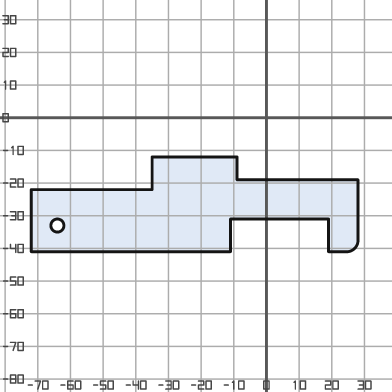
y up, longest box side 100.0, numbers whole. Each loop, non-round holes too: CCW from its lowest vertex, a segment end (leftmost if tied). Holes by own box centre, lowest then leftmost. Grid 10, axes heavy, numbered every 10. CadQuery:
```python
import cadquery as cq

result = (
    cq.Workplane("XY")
    .moveTo(-72.0, -41.0)
    .lineTo(-11.0, -41.0)
    .lineTo(-11.0, -31.0)
    .lineTo(19.0, -31.0)
    .lineTo(19.0, -41.0)
    .lineTo(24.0, -41.0)
    .threePointArc((27.0, -40.0), (28.0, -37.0))
    .lineTo(28.0, -19.0)
    .lineTo(-9.0, -19.0)
    .lineTo(-9.0, -12.0)
    .lineTo(-35.0, -12.0)
    .lineTo(-35.0, -22.0)
    .lineTo(-72.0, -22.0)
    .close()
    .moveTo(-64.0, -33.0)
    .circle(2.0)
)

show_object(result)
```